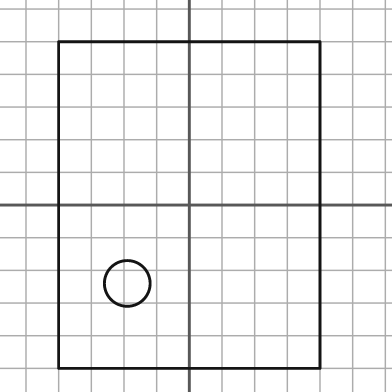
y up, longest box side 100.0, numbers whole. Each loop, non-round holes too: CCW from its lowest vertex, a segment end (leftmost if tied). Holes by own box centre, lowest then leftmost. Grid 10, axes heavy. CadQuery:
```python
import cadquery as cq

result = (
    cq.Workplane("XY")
    .moveTo(-40.0, -50.0)
    .lineTo(40.0, -50.0)
    .lineTo(40.0, 50.0)
    .lineTo(-40.0, 50.0)
    .close()
    .moveTo(-19.0, -24.0)
    .circle(7.0)
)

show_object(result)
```